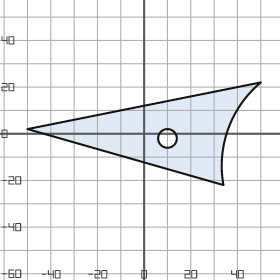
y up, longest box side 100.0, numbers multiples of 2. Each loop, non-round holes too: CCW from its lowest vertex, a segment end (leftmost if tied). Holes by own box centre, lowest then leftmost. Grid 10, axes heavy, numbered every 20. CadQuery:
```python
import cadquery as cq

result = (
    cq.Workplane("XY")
    .moveTo(34.0, -22.0)
    .threePointArc((36.0, 2.0), (50.0, 22.0))
    .lineTo(-50.0, 2.0)
    .close()
    .moveTo(10.0, -2.0)
    .circle(4.0)
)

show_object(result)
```